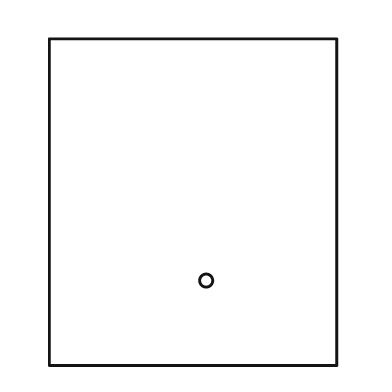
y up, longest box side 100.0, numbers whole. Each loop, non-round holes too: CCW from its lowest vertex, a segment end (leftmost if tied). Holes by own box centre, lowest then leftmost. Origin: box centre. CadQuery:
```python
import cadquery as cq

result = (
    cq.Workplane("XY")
    .moveTo(-44.0, -50.0)
    .lineTo(44.0, -50.0)
    .lineTo(44.0, 50.0)
    .lineTo(-44.0, 50.0)
    .close()
    .moveTo(4.0, -24.0)
    .circle(2.0)
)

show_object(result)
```